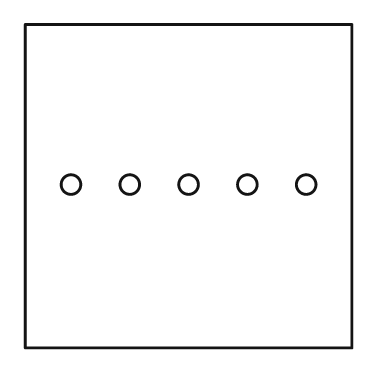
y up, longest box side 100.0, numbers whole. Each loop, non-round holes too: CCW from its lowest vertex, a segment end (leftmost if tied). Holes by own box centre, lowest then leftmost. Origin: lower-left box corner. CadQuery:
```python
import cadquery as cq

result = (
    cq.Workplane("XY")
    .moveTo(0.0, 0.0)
    .lineTo(100.0, 0.0)
    .lineTo(100.0, 99.0)
    .lineTo(0.0, 99.0)
    .close()
    .moveTo(14.0, 50.0)
    .circle(3.0)
    .moveTo(32.0, 50.0)
    .circle(3.0)
    .moveTo(50.0, 50.0)
    .circle(3.0)
    .moveTo(68.0, 50.0)
    .circle(3.0)
    .moveTo(86.0, 50.0)
    .circle(3.0)
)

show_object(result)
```